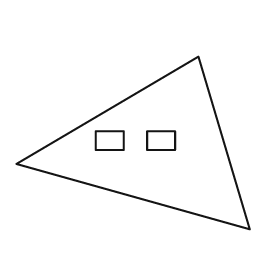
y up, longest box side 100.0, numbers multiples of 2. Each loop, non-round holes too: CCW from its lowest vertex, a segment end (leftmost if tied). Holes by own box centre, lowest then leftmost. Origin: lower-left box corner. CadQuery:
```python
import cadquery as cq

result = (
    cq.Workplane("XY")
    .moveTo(100.0, 0.0)
    .lineTo(78.0, 74.0)
    .lineTo(0.0, 28.0)
    .close()
    .moveTo(34.0, 34.0)
    .lineTo(46.0, 34.0)
    .lineTo(46.0, 42.0)
    .lineTo(34.0, 42.0)
    .close()
    .moveTo(56.0, 34.0)
    .lineTo(68.0, 34.0)
    .lineTo(68.0, 42.0)
    .lineTo(56.0, 42.0)
    .close()
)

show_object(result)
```